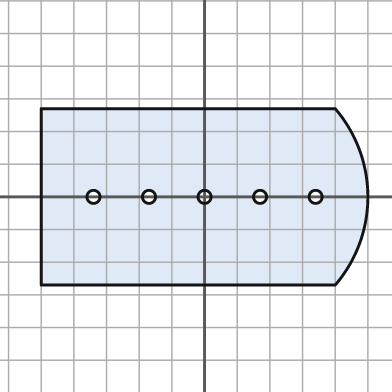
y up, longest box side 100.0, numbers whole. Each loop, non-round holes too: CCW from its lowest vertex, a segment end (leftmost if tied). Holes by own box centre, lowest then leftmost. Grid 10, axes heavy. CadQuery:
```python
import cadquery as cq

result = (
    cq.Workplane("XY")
    .moveTo(-50.0, -27.0)
    .lineTo(40.0, -27.0)
    .threePointArc((50.0, 0.0), (40.0, 27.0))
    .lineTo(-50.0, 27.0)
    .close()
    .moveTo(-34.0, 0.0)
    .circle(2.0)
    .moveTo(-17.0, 0.0)
    .circle(2.0)
    .moveTo(0.0, 0.0)
    .circle(2.0)
    .moveTo(17.0, 0.0)
    .circle(2.0)
    .moveTo(34.0, 0.0)
    .circle(2.0)
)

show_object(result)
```